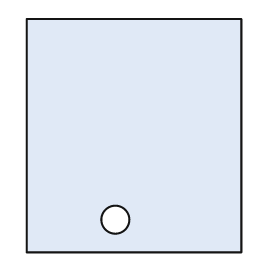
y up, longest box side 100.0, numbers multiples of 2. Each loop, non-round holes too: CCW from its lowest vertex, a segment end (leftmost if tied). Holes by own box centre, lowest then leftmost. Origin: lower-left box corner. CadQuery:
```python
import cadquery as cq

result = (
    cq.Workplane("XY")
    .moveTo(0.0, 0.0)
    .lineTo(92.0, 0.0)
    .lineTo(92.0, 100.0)
    .lineTo(0.0, 100.0)
    .close()
    .moveTo(38.0, 14.0)
    .circle(6.0)
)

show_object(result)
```